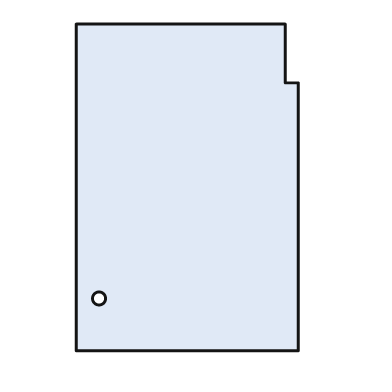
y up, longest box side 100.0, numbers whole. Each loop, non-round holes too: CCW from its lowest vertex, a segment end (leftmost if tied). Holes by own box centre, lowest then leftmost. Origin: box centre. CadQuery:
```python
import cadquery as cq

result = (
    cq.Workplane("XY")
    .moveTo(-34.0, -50.0)
    .lineTo(34.0, -50.0)
    .lineTo(34.0, 32.0)
    .lineTo(30.0, 32.0)
    .lineTo(30.0, 50.0)
    .lineTo(-34.0, 50.0)
    .close()
    .moveTo(-27.0, -34.0)
    .circle(2.0)
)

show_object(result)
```